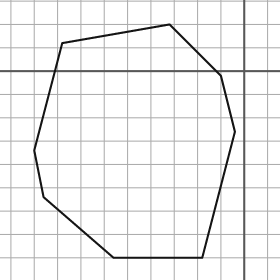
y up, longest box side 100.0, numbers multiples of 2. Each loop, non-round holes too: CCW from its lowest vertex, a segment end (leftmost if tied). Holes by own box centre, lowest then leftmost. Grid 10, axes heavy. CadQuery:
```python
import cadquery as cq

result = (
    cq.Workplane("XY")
    .moveTo(-56.0, -80.0)
    .lineTo(-18.0, -80.0)
    .lineTo(-4.0, -26.0)
    .lineTo(-10.0, -2.0)
    .lineTo(-32.0, 20.0)
    .lineTo(-78.0, 12.0)
    .lineTo(-90.0, -34.0)
    .lineTo(-86.0, -54.0)
    .close()
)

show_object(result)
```